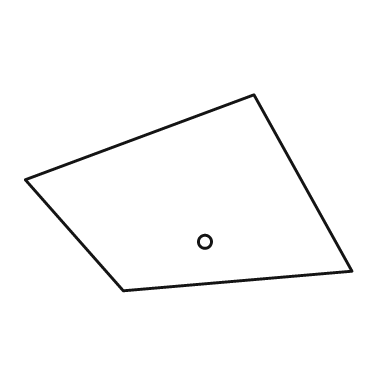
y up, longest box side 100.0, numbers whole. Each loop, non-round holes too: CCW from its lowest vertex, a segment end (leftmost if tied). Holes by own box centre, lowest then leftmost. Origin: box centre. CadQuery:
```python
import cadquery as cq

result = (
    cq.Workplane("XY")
    .moveTo(-20.0, -30.0)
    .lineTo(50.0, -24.0)
    .lineTo(20.0, 30.0)
    .lineTo(-50.0, 4.0)
    .close()
    .moveTo(5.0, -15.0)
    .circle(2.0)
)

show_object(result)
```